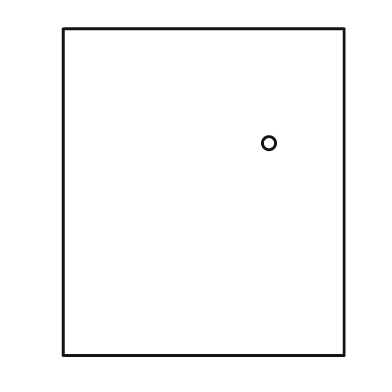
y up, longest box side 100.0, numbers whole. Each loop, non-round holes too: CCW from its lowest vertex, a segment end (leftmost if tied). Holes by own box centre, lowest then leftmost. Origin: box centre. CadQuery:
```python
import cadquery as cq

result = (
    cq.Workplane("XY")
    .moveTo(-43.0, -50.0)
    .lineTo(43.0, -50.0)
    .lineTo(43.0, 50.0)
    .lineTo(-43.0, 50.0)
    .close()
    .moveTo(20.0, 15.0)
    .circle(2.0)
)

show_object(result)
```